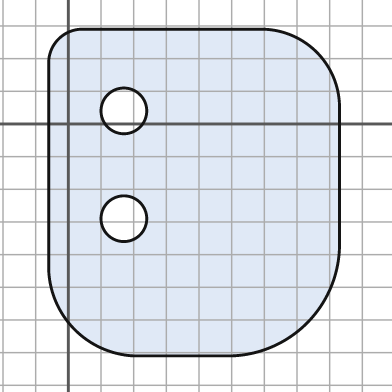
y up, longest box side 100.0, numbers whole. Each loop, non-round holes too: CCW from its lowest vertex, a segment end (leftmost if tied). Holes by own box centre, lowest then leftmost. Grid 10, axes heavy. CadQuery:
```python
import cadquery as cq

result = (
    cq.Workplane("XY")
    .moveTo(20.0, -71.0)
    .lineTo(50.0, -71.0)
    .threePointArc((73.0, -61.0), (83.0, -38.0))
    .lineTo(83.0, 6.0)
    .threePointArc((76.0, 22.0), (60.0, 29.0))
    .lineTo(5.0, 29.0)
    .threePointArc((-3.0, 26.0), (-6.0, 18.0))
    .lineTo(-6.0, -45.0)
    .threePointArc((2.0, -63.0), (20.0, -71.0))
    .close()
    .moveTo(17.0, -29.0)
    .circle(7.0)
    .moveTo(17.0, 4.0)
    .circle(7.0)
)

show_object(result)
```